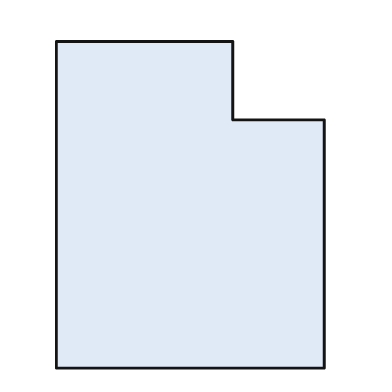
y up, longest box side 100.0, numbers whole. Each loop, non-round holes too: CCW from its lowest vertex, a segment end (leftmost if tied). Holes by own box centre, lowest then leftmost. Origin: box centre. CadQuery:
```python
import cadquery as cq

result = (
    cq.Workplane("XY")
    .moveTo(-41.0, -50.0)
    .lineTo(41.0, -50.0)
    .lineTo(41.0, 26.0)
    .lineTo(13.0, 26.0)
    .lineTo(13.0, 50.0)
    .lineTo(-41.0, 50.0)
    .close()
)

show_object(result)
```